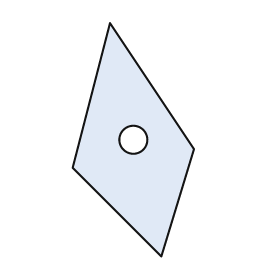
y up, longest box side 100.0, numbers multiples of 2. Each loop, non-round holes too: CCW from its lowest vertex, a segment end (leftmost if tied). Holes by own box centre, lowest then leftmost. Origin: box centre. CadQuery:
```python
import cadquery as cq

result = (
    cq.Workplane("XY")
    .moveTo(12.0, -50.0)
    .lineTo(26.0, -4.0)
    .lineTo(-10.0, 50.0)
    .lineTo(-26.0, -12.0)
    .close()
    .moveTo(0.0, 0.0)
    .circle(6.0)
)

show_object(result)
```